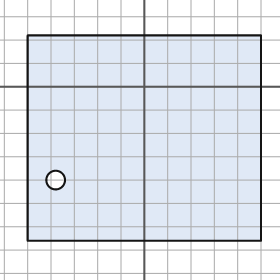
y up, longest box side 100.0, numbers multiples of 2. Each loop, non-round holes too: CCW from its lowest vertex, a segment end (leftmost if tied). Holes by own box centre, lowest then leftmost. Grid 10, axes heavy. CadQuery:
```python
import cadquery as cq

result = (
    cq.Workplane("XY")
    .moveTo(-50.0, -66.0)
    .lineTo(50.0, -66.0)
    .lineTo(50.0, 22.0)
    .lineTo(-50.0, 22.0)
    .close()
    .moveTo(-38.0, -40.0)
    .circle(4.0)
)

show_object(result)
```